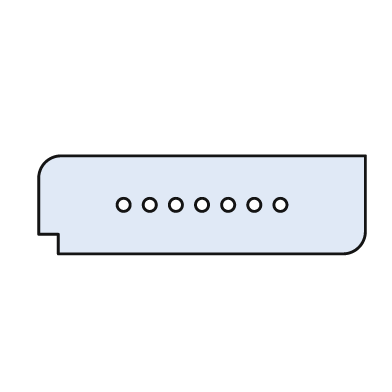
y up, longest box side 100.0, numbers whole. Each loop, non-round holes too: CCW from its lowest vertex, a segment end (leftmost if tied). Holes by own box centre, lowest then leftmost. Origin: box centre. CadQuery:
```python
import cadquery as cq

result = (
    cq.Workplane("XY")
    .moveTo(-44.0, -15.0)
    .lineTo(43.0, -15.0)
    .threePointArc((48.0, -13.0), (50.0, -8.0))
    .lineTo(50.0, 15.0)
    .lineTo(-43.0, 15.0)
    .threePointArc((-48.0, 13.0), (-50.0, 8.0))
    .lineTo(-50.0, -9.0)
    .lineTo(-44.0, -9.0)
    .close()
    .moveTo(-24.0, 0.0)
    .circle(2.0)
    .moveTo(-16.0, 0.0)
    .circle(2.0)
    .moveTo(-8.0, 0.0)
    .circle(2.0)
    .moveTo(0.0, 0.0)
    .circle(2.0)
    .moveTo(8.0, 0.0)
    .circle(2.0)
    .moveTo(16.0, 0.0)
    .circle(2.0)
    .moveTo(24.0, 0.0)
    .circle(2.0)
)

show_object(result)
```